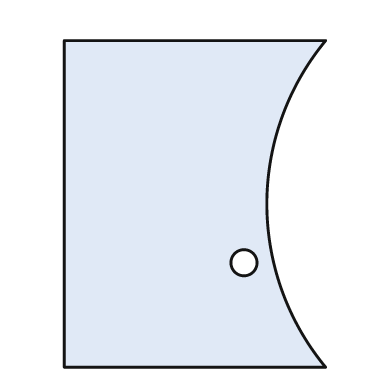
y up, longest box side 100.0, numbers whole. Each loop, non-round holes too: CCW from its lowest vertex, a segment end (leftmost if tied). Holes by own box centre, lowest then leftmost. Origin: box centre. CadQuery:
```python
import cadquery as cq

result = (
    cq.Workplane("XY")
    .moveTo(-40.0, -50.0)
    .lineTo(40.0, -50.0)
    .threePointArc((22.0, 0.0), (40.0, 50.0))
    .lineTo(-40.0, 50.0)
    .close()
    .moveTo(15.0, -18.0)
    .circle(4.0)
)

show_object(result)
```